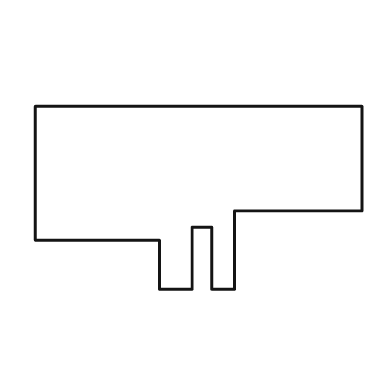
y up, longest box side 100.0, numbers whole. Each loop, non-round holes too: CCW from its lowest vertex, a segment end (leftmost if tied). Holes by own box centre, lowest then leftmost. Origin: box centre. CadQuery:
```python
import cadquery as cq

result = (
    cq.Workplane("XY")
    .moveTo(-12.0, -28.0)
    .lineTo(-2.0, -28.0)
    .lineTo(-2.0, -9.0)
    .lineTo(4.0, -9.0)
    .lineTo(4.0, -28.0)
    .lineTo(11.0, -28.0)
    .lineTo(11.0, -4.0)
    .lineTo(50.0, -4.0)
    .lineTo(50.0, 28.0)
    .lineTo(-50.0, 28.0)
    .lineTo(-50.0, -13.0)
    .lineTo(-12.0, -13.0)
    .close()
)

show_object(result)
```